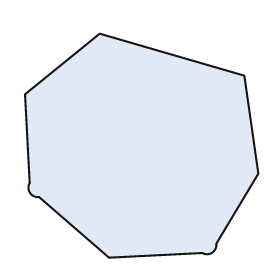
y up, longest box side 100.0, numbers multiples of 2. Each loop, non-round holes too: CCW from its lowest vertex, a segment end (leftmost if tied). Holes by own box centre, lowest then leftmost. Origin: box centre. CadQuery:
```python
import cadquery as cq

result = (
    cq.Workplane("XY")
    .moveTo(-14.0, -48.0)
    .lineTo(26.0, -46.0)
    .threePointArc((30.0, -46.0), (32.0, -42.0))
    .lineTo(50.0, -12.0)
    .lineTo(44.0, 30.0)
    .lineTo(-18.0, 48.0)
    .lineTo(-50.0, 22.0)
    .lineTo(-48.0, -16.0)
    .threePointArc((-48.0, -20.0), (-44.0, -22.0))
    .close()
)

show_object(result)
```